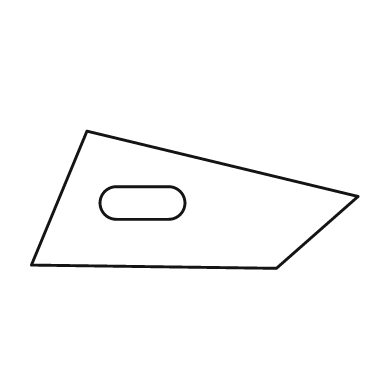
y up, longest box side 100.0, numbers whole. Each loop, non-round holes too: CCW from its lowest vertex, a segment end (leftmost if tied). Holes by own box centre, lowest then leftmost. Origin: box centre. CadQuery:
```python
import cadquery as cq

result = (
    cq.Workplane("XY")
    .moveTo(25.0, -21.0)
    .lineTo(50.0, 1.0)
    .lineTo(-33.0, 21.0)
    .lineTo(-50.0, -20.0)
    .close()
    .moveTo(-24.0, -6.0)
    .lineTo(-8.0, -6.0)
    .threePointArc((-3.0, -1.0), (-8.0, 4.0))
    .lineTo(-24.0, 4.0)
    .threePointArc((-29.0, -1.0), (-24.0, -6.0))
    .close()
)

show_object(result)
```